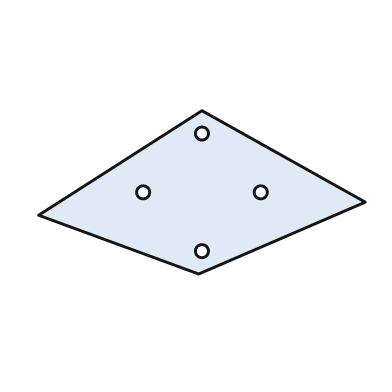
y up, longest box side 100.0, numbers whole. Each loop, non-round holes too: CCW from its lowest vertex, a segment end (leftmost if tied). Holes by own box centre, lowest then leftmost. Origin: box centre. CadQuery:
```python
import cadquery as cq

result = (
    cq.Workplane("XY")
    .moveTo(-1.0, -25.0)
    .lineTo(50.0, -3.0)
    .lineTo(0.0, 25.0)
    .lineTo(-50.0, -7.0)
    .close()
    .moveTo(0.0, -18.0)
    .circle(2.0)
    .moveTo(-18.0, 0.0)
    .circle(2.0)
    .moveTo(18.0, 0.0)
    .circle(2.0)
    .moveTo(0.0, 18.0)
    .circle(2.0)
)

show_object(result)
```